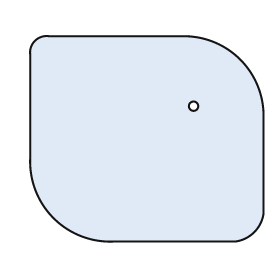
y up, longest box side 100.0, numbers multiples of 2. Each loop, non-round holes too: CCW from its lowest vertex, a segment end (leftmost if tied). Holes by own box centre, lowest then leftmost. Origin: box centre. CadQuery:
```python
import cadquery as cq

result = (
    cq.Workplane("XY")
    .moveTo(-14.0, -44.0)
    .lineTo(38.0, -44.0)
    .threePointArc((46.0, -40.0), (50.0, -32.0))
    .lineTo(50.0, 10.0)
    .threePointArc((40.0, 34.0), (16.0, 44.0))
    .lineTo(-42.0, 44.0)
    .threePointArc((-48.0, 42.0), (-50.0, 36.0))
    .lineTo(-50.0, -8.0)
    .threePointArc((-40.0, -34.0), (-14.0, -44.0))
    .close()
    .moveTo(20.0, 14.0)
    .circle(2.0)
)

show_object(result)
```